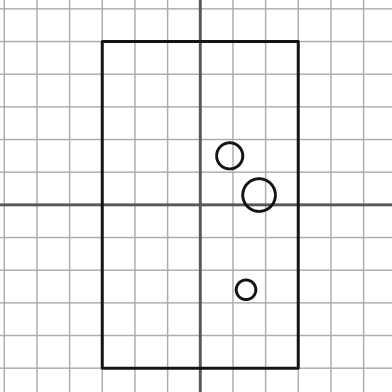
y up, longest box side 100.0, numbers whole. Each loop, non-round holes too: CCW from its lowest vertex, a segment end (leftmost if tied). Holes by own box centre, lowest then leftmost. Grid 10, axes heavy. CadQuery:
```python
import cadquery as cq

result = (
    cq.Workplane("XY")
    .moveTo(-30.0, -50.0)
    .lineTo(30.0, -50.0)
    .lineTo(30.0, 50.0)
    .lineTo(-30.0, 50.0)
    .close()
    .moveTo(14.0, -26.0)
    .circle(3.0)
    .moveTo(18.0, 3.0)
    .circle(5.0)
    .moveTo(9.0, 15.0)
    .circle(4.0)
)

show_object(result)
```